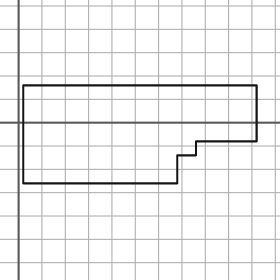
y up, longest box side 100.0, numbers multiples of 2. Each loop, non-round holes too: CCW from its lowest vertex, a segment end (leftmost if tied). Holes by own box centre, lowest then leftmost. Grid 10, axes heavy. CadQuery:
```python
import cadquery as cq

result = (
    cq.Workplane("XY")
    .moveTo(2.0, -26.0)
    .lineTo(68.0, -26.0)
    .lineTo(68.0, -14.0)
    .lineTo(76.0, -14.0)
    .lineTo(76.0, -8.0)
    .lineTo(102.0, -8.0)
    .lineTo(102.0, 16.0)
    .lineTo(2.0, 16.0)
    .close()
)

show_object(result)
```